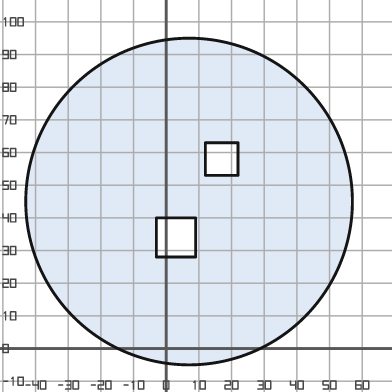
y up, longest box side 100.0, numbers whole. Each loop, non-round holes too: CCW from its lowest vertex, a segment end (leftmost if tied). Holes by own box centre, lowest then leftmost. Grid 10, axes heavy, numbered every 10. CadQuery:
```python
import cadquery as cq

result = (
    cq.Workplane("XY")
    .moveTo(7.0, 45.0)
    .circle(50.0)
    .moveTo(-3.0, 28.0)
    .lineTo(9.0, 28.0)
    .lineTo(9.0, 40.0)
    .lineTo(-3.0, 40.0)
    .close()
    .moveTo(12.0, 53.0)
    .lineTo(22.0, 53.0)
    .lineTo(22.0, 63.0)
    .lineTo(12.0, 63.0)
    .close()
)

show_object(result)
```